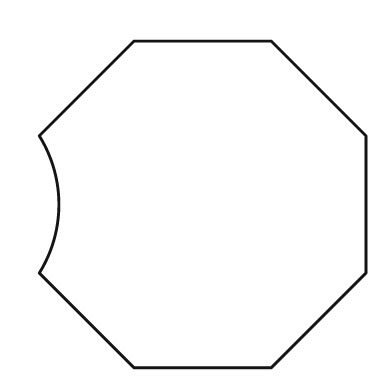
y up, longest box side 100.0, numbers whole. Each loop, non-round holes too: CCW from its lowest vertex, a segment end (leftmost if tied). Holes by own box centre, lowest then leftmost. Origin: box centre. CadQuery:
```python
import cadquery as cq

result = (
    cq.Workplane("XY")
    .moveTo(-21.0, -50.0)
    .lineTo(21.0, -50.0)
    .lineTo(50.0, -21.0)
    .lineTo(50.0, 21.0)
    .lineTo(21.0, 50.0)
    .lineTo(-21.0, 50.0)
    .lineTo(-50.0, 21.0)
    .threePointArc((-44.0, 0.0), (-50.0, -21.0))
    .close()
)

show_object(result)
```